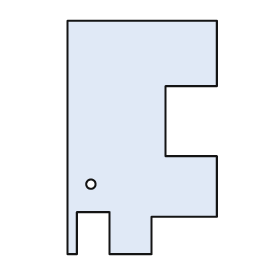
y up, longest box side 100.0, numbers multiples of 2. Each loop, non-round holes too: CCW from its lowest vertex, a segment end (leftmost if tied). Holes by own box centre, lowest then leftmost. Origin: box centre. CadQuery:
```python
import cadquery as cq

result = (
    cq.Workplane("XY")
    .moveTo(-32.0, -50.0)
    .lineTo(-28.0, -50.0)
    .lineTo(-28.0, -32.0)
    .lineTo(-14.0, -32.0)
    .lineTo(-14.0, -50.0)
    .lineTo(4.0, -50.0)
    .lineTo(4.0, -34.0)
    .lineTo(32.0, -34.0)
    .lineTo(32.0, -8.0)
    .lineTo(10.0, -8.0)
    .lineTo(10.0, 22.0)
    .lineTo(32.0, 22.0)
    .lineTo(32.0, 50.0)
    .lineTo(-32.0, 50.0)
    .close()
    .moveTo(-22.0, -20.0)
    .circle(2.0)
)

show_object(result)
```